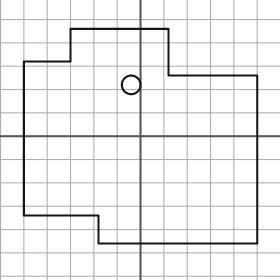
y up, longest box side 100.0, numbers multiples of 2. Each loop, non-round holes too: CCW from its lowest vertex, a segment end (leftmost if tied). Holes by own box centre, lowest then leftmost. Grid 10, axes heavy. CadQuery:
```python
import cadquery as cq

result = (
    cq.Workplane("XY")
    .moveTo(-18.0, -46.0)
    .lineTo(50.0, -46.0)
    .lineTo(50.0, 26.0)
    .lineTo(12.0, 26.0)
    .lineTo(12.0, 46.0)
    .lineTo(-30.0, 46.0)
    .lineTo(-30.0, 32.0)
    .lineTo(-50.0, 32.0)
    .lineTo(-50.0, -34.0)
    .lineTo(-18.0, -34.0)
    .close()
    .moveTo(-4.0, 22.0)
    .circle(4.0)
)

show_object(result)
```